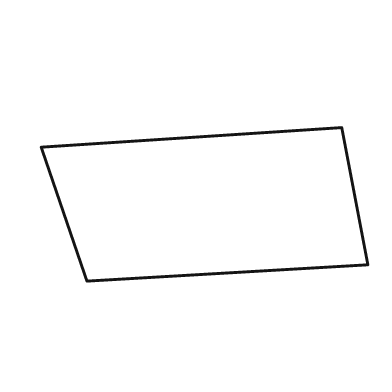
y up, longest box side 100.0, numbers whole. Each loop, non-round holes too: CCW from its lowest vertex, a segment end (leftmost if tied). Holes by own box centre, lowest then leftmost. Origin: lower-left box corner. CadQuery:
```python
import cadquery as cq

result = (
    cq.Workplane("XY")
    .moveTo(14.0, 0.0)
    .lineTo(100.0, 5.0)
    .lineTo(92.0, 47.0)
    .lineTo(0.0, 41.0)
    .close()
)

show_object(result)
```